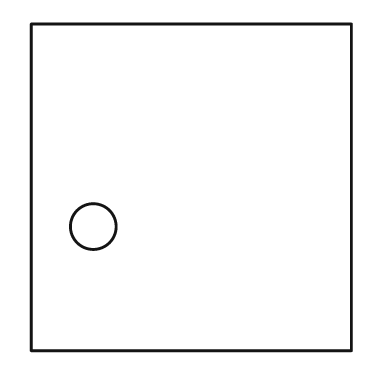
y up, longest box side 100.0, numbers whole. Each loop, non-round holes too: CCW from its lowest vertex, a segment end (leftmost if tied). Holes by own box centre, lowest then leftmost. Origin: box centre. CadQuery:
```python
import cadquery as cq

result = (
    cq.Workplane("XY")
    .moveTo(-49.0, -50.0)
    .lineTo(49.0, -50.0)
    .lineTo(49.0, 50.0)
    .lineTo(-49.0, 50.0)
    .close()
    .moveTo(-30.0, -12.0)
    .circle(7.0)
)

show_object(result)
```